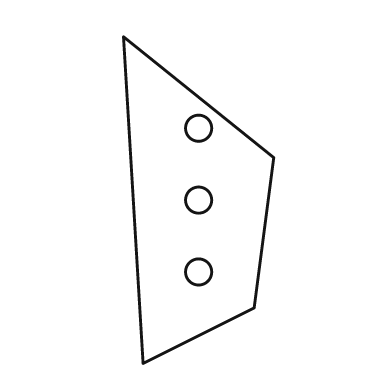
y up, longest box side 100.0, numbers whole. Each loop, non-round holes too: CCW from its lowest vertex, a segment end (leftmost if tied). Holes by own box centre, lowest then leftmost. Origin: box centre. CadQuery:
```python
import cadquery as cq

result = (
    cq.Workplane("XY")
    .moveTo(-17.0, -50.0)
    .lineTo(17.0, -33.0)
    .lineTo(23.0, 13.0)
    .lineTo(-23.0, 50.0)
    .close()
    .moveTo(0.0, -22.0)
    .circle(4.0)
    .moveTo(0.0, 0.0)
    .circle(4.0)
    .moveTo(0.0, 22.0)
    .circle(4.0)
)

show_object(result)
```